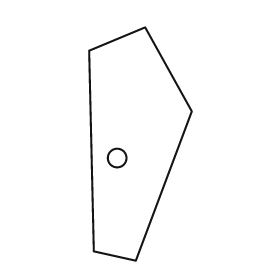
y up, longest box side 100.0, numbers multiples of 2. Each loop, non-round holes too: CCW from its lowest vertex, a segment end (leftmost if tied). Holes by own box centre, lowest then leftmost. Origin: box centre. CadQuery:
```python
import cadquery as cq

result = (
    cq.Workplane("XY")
    .moveTo(-2.0, -50.0)
    .lineTo(22.0, 14.0)
    .lineTo(2.0, 50.0)
    .lineTo(-22.0, 40.0)
    .lineTo(-20.0, -46.0)
    .close()
    .moveTo(-10.0, -6.0)
    .circle(4.0)
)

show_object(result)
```